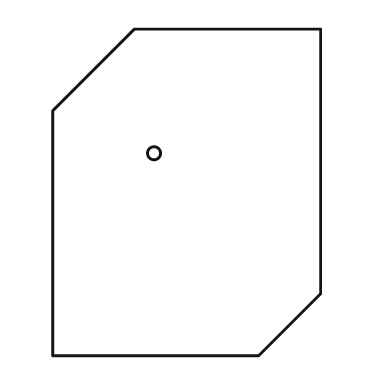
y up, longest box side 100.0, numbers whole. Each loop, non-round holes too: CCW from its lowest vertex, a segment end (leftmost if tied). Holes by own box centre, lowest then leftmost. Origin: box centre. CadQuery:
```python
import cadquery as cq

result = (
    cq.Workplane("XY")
    .moveTo(-41.0, -50.0)
    .lineTo(22.0, -50.0)
    .lineTo(41.0, -31.0)
    .lineTo(41.0, 50.0)
    .lineTo(-16.0, 50.0)
    .lineTo(-41.0, 25.0)
    .close()
    .moveTo(-10.0, 12.0)
    .circle(2.0)
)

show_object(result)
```